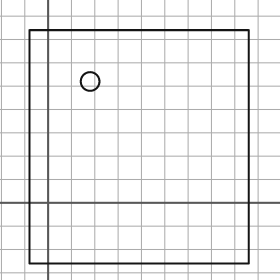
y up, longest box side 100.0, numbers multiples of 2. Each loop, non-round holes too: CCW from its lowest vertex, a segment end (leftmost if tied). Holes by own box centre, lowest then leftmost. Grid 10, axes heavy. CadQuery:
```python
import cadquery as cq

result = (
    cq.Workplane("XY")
    .moveTo(-8.0, -26.0)
    .lineTo(86.0, -26.0)
    .lineTo(86.0, 74.0)
    .lineTo(-8.0, 74.0)
    .close()
    .moveTo(18.0, 52.0)
    .circle(4.0)
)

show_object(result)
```